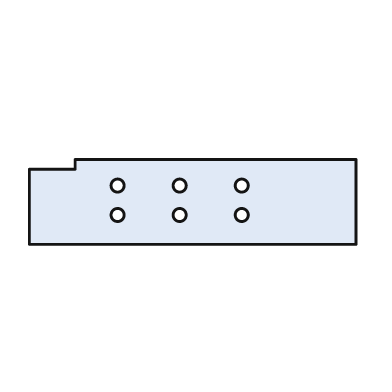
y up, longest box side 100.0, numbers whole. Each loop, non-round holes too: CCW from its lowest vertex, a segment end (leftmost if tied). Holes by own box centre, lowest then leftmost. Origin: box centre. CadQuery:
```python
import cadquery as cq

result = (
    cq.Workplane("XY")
    .moveTo(-50.0, -13.0)
    .lineTo(50.0, -13.0)
    .lineTo(50.0, 13.0)
    .lineTo(-36.0, 13.0)
    .lineTo(-36.0, 10.0)
    .lineTo(-50.0, 10.0)
    .close()
    .moveTo(-23.0, -4.0)
    .circle(2.0)
    .moveTo(-4.0, -4.0)
    .circle(2.0)
    .moveTo(15.0, -4.0)
    .circle(2.0)
    .moveTo(-23.0, 5.0)
    .circle(2.0)
    .moveTo(-4.0, 5.0)
    .circle(2.0)
    .moveTo(15.0, 5.0)
    .circle(2.0)
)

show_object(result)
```